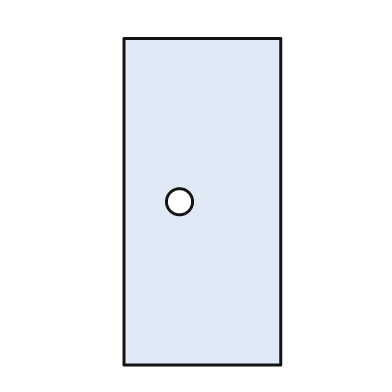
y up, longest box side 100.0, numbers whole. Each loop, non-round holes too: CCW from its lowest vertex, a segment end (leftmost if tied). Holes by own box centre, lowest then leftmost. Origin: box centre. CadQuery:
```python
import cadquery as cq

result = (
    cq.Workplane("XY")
    .moveTo(-24.0, -50.0)
    .lineTo(24.0, -50.0)
    .lineTo(24.0, 50.0)
    .lineTo(-24.0, 50.0)
    .close()
    .moveTo(-7.0, 0.0)
    .circle(4.0)
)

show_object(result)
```